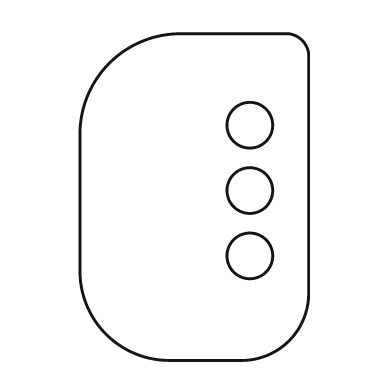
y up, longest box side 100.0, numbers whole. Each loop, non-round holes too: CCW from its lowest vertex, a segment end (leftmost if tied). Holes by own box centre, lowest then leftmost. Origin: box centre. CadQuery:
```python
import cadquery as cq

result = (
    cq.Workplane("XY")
    .moveTo(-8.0, -50.0)
    .lineTo(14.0, -50.0)
    .threePointArc((29.0, -44.0), (35.0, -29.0))
    .lineTo(35.0, 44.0)
    .threePointArc((33.0, 48.0), (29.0, 50.0))
    .lineTo(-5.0, 50.0)
    .threePointArc((-26.0, 41.0), (-35.0, 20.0))
    .lineTo(-35.0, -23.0)
    .threePointArc((-27.0, -42.0), (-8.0, -50.0))
    .close()
    .moveTo(17.0, -18.0)
    .circle(7.0)
    .moveTo(17.0, 2.0)
    .circle(7.0)
    .moveTo(17.0, 22.0)
    .circle(7.0)
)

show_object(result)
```